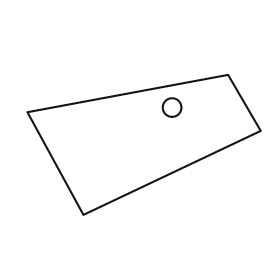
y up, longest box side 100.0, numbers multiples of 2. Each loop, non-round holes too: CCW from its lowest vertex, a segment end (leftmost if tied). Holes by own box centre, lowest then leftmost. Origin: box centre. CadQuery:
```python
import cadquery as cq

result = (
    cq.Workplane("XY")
    .moveTo(-26.0, -30.0)
    .lineTo(50.0, 6.0)
    .lineTo(36.0, 30.0)
    .lineTo(-50.0, 14.0)
    .close()
    .moveTo(12.0, 16.0)
    .circle(4.0)
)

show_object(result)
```